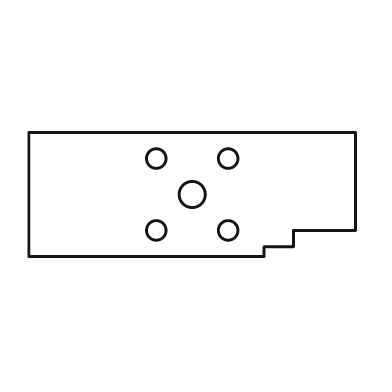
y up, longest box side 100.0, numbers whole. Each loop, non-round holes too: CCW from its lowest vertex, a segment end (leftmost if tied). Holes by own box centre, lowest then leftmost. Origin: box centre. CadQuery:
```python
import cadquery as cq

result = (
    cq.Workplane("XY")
    .moveTo(-50.0, -19.0)
    .lineTo(22.0, -19.0)
    .lineTo(22.0, -16.0)
    .lineTo(31.0, -16.0)
    .lineTo(31.0, -11.0)
    .lineTo(50.0, -11.0)
    .lineTo(50.0, 19.0)
    .lineTo(-50.0, 19.0)
    .close()
    .moveTo(-11.0, -11.0)
    .circle(3.0)
    .moveTo(11.0, -11.0)
    .circle(3.0)
    .moveTo(0.0, 0.0)
    .circle(4.0)
    .moveTo(-11.0, 11.0)
    .circle(3.0)
    .moveTo(11.0, 11.0)
    .circle(3.0)
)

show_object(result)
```